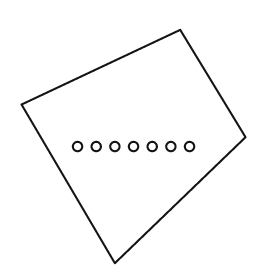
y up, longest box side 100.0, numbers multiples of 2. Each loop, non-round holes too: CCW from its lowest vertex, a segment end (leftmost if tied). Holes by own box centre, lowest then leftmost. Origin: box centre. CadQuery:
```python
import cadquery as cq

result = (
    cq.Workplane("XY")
    .moveTo(-8.0, -50.0)
    .lineTo(48.0, 4.0)
    .lineTo(20.0, 50.0)
    .lineTo(-48.0, 18.0)
    .close()
    .moveTo(-24.0, 0.0)
    .circle(2.0)
    .moveTo(-16.0, 0.0)
    .circle(2.0)
    .moveTo(-8.0, 0.0)
    .circle(2.0)
    .moveTo(0.0, 0.0)
    .circle(2.0)
    .moveTo(8.0, 0.0)
    .circle(2.0)
    .moveTo(16.0, 0.0)
    .circle(2.0)
    .moveTo(24.0, 0.0)
    .circle(2.0)
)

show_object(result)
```